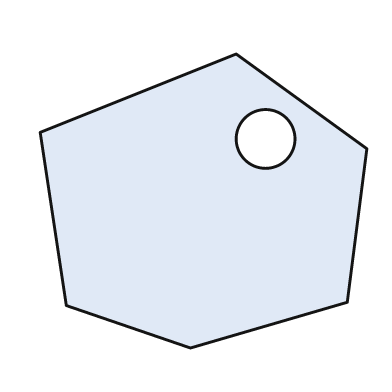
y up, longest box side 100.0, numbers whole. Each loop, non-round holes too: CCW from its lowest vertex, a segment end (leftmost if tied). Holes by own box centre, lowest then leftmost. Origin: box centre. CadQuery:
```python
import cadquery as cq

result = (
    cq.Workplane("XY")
    .moveTo(-4.0, -45.0)
    .lineTo(44.0, -31.0)
    .lineTo(50.0, 16.0)
    .lineTo(10.0, 45.0)
    .lineTo(-50.0, 21.0)
    .lineTo(-42.0, -32.0)
    .close()
    .moveTo(19.0, 19.0)
    .circle(9.0)
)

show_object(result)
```